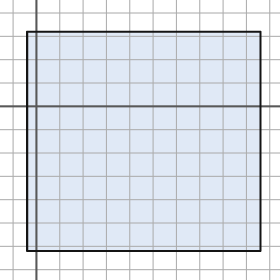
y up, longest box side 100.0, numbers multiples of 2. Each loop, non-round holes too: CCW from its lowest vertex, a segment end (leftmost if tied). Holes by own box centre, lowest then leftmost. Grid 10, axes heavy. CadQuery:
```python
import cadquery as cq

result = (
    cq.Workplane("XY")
    .moveTo(-4.0, -62.0)
    .lineTo(96.0, -62.0)
    .lineTo(96.0, 32.0)
    .lineTo(-4.0, 32.0)
    .close()
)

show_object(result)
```